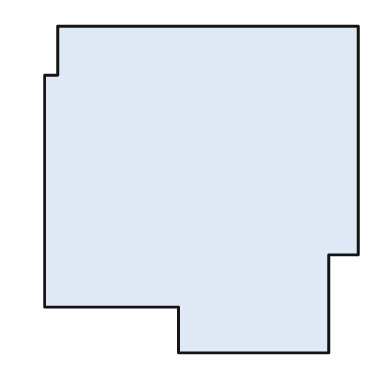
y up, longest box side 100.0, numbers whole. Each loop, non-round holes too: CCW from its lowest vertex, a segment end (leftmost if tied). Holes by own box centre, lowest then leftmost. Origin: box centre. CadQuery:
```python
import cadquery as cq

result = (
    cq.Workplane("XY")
    .moveTo(-7.0, -50.0)
    .lineTo(39.0, -50.0)
    .lineTo(39.0, -20.0)
    .lineTo(48.0, -20.0)
    .lineTo(48.0, 50.0)
    .lineTo(-44.0, 50.0)
    .lineTo(-44.0, 35.0)
    .lineTo(-48.0, 35.0)
    .lineTo(-48.0, -36.0)
    .lineTo(-7.0, -36.0)
    .close()
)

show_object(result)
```